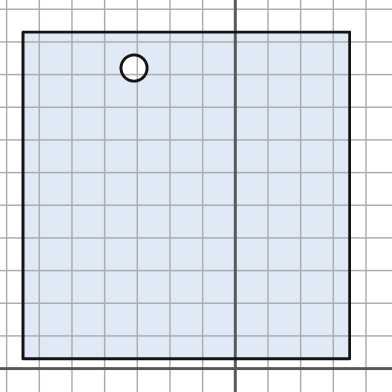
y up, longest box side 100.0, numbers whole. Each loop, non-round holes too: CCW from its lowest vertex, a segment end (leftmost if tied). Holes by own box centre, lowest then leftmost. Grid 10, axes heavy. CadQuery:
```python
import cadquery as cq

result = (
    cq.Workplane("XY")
    .moveTo(-65.0, 3.0)
    .lineTo(35.0, 3.0)
    .lineTo(35.0, 103.0)
    .lineTo(-65.0, 103.0)
    .close()
    .moveTo(-31.0, 92.0)
    .circle(4.0)
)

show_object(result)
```